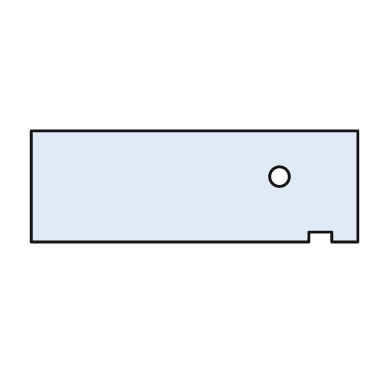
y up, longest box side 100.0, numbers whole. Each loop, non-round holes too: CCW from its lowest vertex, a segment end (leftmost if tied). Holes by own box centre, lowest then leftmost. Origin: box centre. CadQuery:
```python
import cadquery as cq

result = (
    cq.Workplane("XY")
    .moveTo(-50.0, -17.0)
    .lineTo(35.0, -17.0)
    .lineTo(35.0, -14.0)
    .lineTo(42.0, -14.0)
    .lineTo(42.0, -17.0)
    .lineTo(50.0, -17.0)
    .lineTo(50.0, 17.0)
    .lineTo(-50.0, 17.0)
    .close()
    .moveTo(26.0, 3.0)
    .circle(3.0)
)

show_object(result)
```